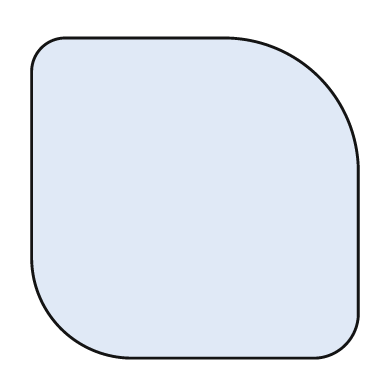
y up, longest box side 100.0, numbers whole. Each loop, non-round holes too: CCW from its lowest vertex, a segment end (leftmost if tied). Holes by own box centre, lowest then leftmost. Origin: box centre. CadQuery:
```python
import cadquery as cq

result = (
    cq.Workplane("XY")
    .moveTo(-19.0, -49.0)
    .lineTo(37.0, -49.0)
    .threePointArc((46.0, -45.0), (50.0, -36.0))
    .lineTo(50.0, 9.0)
    .threePointArc((38.0, 37.0), (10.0, 49.0))
    .lineTo(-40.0, 49.0)
    .threePointArc((-47.0, 46.0), (-50.0, 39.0))
    .lineTo(-50.0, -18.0)
    .threePointArc((-41.0, -40.0), (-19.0, -49.0))
    .close()
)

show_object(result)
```